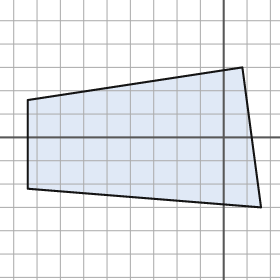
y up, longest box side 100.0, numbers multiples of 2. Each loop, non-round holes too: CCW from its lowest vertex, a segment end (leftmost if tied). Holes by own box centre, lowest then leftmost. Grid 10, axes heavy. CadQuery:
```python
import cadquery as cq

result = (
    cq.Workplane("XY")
    .moveTo(16.0, -30.0)
    .lineTo(8.0, 30.0)
    .lineTo(-84.0, 16.0)
    .lineTo(-84.0, -22.0)
    .close()
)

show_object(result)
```